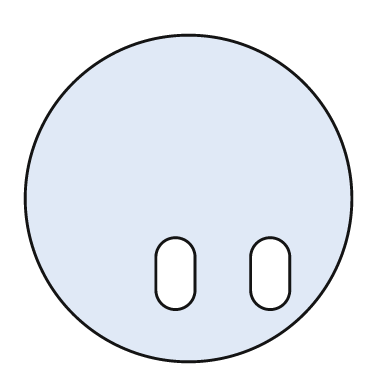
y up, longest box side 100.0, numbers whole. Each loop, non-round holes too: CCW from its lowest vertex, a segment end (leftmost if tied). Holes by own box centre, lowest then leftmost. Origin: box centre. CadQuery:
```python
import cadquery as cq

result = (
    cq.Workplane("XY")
    .moveTo(0.0, 0.0)
    .circle(50.0)
    .moveTo(-10.0, -28.0)
    .threePointArc((-4.0, -34.0), (2.0, -28.0))
    .lineTo(2.0, -18.0)
    .threePointArc((-4.0, -12.0), (-10.0, -18.0))
    .close()
    .moveTo(19.0, -28.0)
    .threePointArc((25.0, -34.0), (31.0, -28.0))
    .lineTo(31.0, -18.0)
    .threePointArc((25.0, -12.0), (19.0, -18.0))
    .close()
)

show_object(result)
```